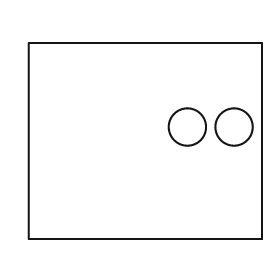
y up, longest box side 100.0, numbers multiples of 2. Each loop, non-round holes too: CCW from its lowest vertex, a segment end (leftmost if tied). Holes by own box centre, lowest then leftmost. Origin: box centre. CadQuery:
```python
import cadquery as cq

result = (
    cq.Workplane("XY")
    .moveTo(-50.0, -42.0)
    .lineTo(50.0, -42.0)
    .lineTo(50.0, 42.0)
    .lineTo(-50.0, 42.0)
    .close()
    .moveTo(18.0, 6.0)
    .circle(8.0)
    .moveTo(38.0, 6.0)
    .circle(8.0)
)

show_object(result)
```